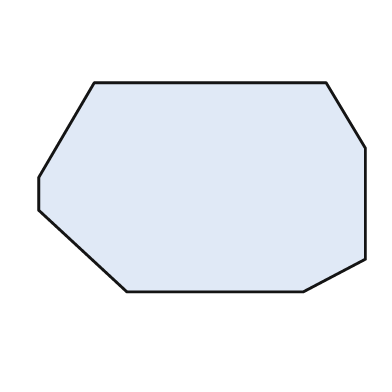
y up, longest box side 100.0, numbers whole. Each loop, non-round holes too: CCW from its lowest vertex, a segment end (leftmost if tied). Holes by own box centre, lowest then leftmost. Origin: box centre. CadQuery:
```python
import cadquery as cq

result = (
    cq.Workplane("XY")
    .moveTo(-23.0, -32.0)
    .lineTo(31.0, -32.0)
    .lineTo(50.0, -22.0)
    .lineTo(50.0, 12.0)
    .lineTo(38.0, 32.0)
    .lineTo(-33.0, 32.0)
    .lineTo(-50.0, 3.0)
    .lineTo(-50.0, -7.0)
    .close()
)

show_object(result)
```